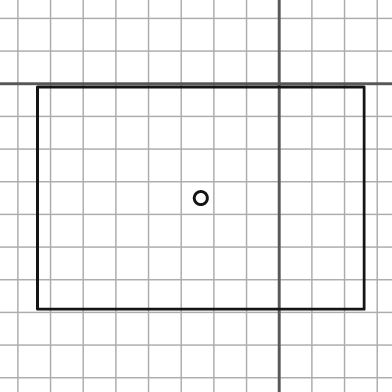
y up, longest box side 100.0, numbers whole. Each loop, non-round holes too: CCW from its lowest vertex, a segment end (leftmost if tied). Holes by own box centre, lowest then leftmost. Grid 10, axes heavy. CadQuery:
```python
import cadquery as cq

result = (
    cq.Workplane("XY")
    .moveTo(-74.0, -69.0)
    .lineTo(26.0, -69.0)
    .lineTo(26.0, -1.0)
    .lineTo(-74.0, -1.0)
    .close()
    .moveTo(-24.0, -35.0)
    .circle(2.0)
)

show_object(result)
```